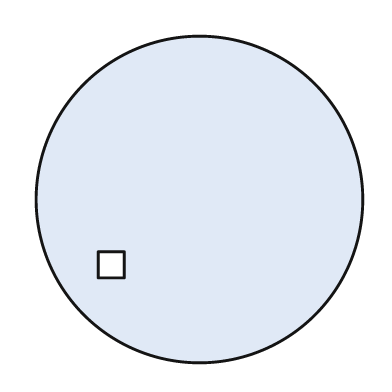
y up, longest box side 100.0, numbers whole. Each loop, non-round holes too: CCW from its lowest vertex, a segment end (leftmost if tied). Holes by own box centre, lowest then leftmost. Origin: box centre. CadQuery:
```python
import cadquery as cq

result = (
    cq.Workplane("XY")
    .moveTo(0.0, 0.0)
    .circle(50.0)
    .moveTo(-31.0, -24.0)
    .lineTo(-23.0, -24.0)
    .lineTo(-23.0, -16.0)
    .lineTo(-31.0, -16.0)
    .close()
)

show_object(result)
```